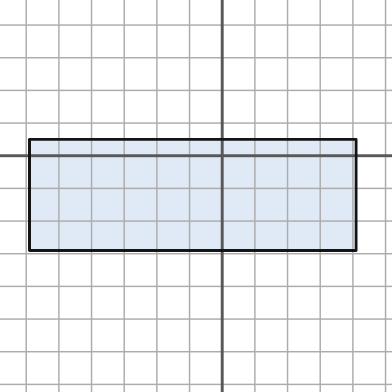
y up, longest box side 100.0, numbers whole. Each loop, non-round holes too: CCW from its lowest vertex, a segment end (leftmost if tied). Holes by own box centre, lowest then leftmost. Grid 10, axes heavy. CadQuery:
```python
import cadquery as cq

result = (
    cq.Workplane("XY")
    .moveTo(-59.0, -29.0)
    .lineTo(41.0, -29.0)
    .lineTo(41.0, 5.0)
    .lineTo(-59.0, 5.0)
    .close()
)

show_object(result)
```